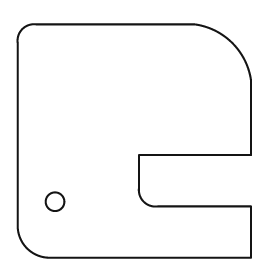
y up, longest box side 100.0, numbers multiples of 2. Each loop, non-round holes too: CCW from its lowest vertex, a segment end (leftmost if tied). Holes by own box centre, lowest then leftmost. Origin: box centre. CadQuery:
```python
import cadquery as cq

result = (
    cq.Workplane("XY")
    .moveTo(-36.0, -50.0)
    .lineTo(50.0, -50.0)
    .lineTo(50.0, -28.0)
    .lineTo(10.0, -28.0)
    .threePointArc((4.0, -26.0), (2.0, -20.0))
    .lineTo(2.0, -6.0)
    .lineTo(50.0, -6.0)
    .lineTo(50.0, 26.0)
    .threePointArc((42.0, 42.0), (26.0, 50.0))
    .lineTo(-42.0, 50.0)
    .threePointArc((-48.0, 48.0), (-50.0, 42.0))
    .lineTo(-50.0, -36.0)
    .threePointArc((-46.0, -46.0), (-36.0, -50.0))
    .close()
    .moveTo(-34.0, -26.0)
    .circle(4.0)
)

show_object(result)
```